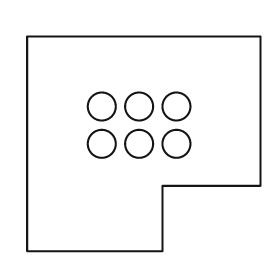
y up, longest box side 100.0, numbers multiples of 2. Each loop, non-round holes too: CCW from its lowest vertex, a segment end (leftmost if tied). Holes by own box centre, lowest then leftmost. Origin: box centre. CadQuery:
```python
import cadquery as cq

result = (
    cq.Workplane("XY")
    .moveTo(-50.0, -46.0)
    .lineTo(8.0, -46.0)
    .lineTo(8.0, -18.0)
    .lineTo(50.0, -18.0)
    .lineTo(50.0, 46.0)
    .lineTo(-50.0, 46.0)
    .close()
    .moveTo(-18.0, 0.0)
    .circle(6.0)
    .moveTo(-2.0, 0.0)
    .circle(6.0)
    .moveTo(14.0, 0.0)
    .circle(6.0)
    .moveTo(-18.0, 16.0)
    .circle(6.0)
    .moveTo(-2.0, 16.0)
    .circle(6.0)
    .moveTo(14.0, 16.0)
    .circle(6.0)
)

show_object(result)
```